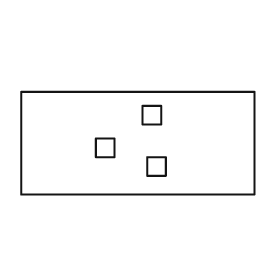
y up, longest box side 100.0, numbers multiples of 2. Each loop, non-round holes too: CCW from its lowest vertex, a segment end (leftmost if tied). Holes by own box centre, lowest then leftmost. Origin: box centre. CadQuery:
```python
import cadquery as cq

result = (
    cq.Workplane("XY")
    .moveTo(-50.0, -22.0)
    .lineTo(50.0, -22.0)
    .lineTo(50.0, 22.0)
    .lineTo(-50.0, 22.0)
    .close()
    .moveTo(4.0, -14.0)
    .lineTo(12.0, -14.0)
    .lineTo(12.0, -6.0)
    .lineTo(4.0, -6.0)
    .close()
    .moveTo(-18.0, -6.0)
    .lineTo(-10.0, -6.0)
    .lineTo(-10.0, 2.0)
    .lineTo(-18.0, 2.0)
    .close()
    .moveTo(2.0, 8.0)
    .lineTo(10.0, 8.0)
    .lineTo(10.0, 16.0)
    .lineTo(2.0, 16.0)
    .close()
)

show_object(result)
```